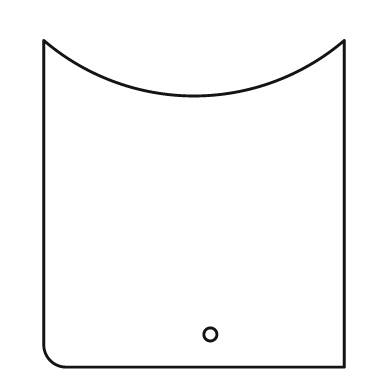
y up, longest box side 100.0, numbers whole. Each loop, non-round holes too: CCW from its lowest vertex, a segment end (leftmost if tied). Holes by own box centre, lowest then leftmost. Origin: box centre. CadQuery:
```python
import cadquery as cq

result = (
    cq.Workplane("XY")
    .moveTo(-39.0, -50.0)
    .lineTo(46.0, -50.0)
    .lineTo(46.0, 50.0)
    .threePointArc((0.0, 33.0), (-46.0, 50.0))
    .lineTo(-46.0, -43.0)
    .threePointArc((-44.0, -48.0), (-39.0, -50.0))
    .close()
    .moveTo(5.0, -40.0)
    .circle(2.0)
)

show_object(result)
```